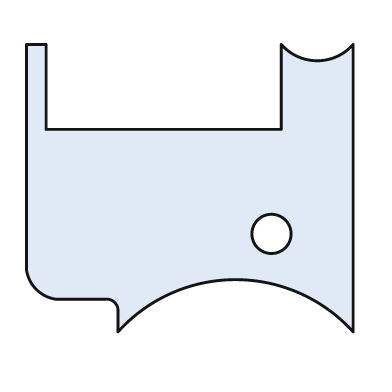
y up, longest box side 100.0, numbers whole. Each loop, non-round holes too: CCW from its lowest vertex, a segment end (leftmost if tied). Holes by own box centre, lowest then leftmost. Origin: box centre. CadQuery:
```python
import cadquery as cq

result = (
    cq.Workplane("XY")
    .moveTo(-22.0, -44.0)
    .threePointArc((14.0, -28.0), (50.0, -44.0))
    .lineTo(50.0, 44.0)
    .threePointArc((39.0, 39.0), (28.0, 44.0))
    .lineTo(28.0, 18.0)
    .lineTo(-44.0, 18.0)
    .lineTo(-44.0, 44.0)
    .lineTo(-50.0, 44.0)
    .lineTo(-50.0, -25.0)
    .threePointArc((-47.0, -31.0), (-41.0, -34.0))
    .lineTo(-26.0, -34.0)
    .threePointArc((-23.0, -35.0), (-22.0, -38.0))
    .close()
    .moveTo(25.0, -14.0)
    .circle(6.0)
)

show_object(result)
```